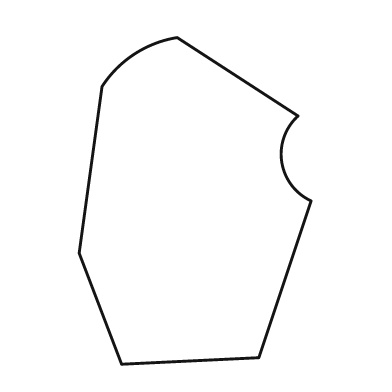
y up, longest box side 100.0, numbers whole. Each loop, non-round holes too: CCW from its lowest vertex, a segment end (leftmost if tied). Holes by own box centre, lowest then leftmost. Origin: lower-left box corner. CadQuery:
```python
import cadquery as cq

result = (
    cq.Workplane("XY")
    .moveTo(13.0, 0.0)
    .lineTo(55.0, 2.0)
    .lineTo(71.0, 50.0)
    .threePointArc((62.0, 62.0), (67.0, 76.0))
    .lineTo(30.0, 100.0)
    .threePointArc((17.0, 95.0), (7.0, 85.0))
    .lineTo(0.0, 34.0)
    .close()
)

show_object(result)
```